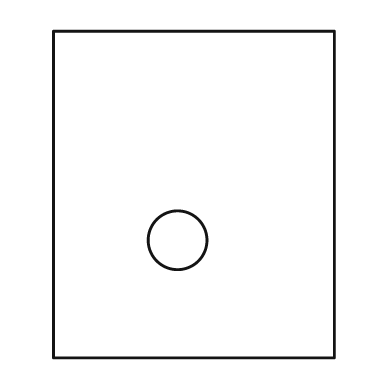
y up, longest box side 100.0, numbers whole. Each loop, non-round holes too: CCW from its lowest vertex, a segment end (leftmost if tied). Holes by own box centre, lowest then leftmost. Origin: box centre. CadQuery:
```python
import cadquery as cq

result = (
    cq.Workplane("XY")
    .moveTo(-43.0, -50.0)
    .lineTo(43.0, -50.0)
    .lineTo(43.0, 50.0)
    .lineTo(-43.0, 50.0)
    .close()
    .moveTo(-5.0, -14.0)
    .circle(9.0)
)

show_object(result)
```